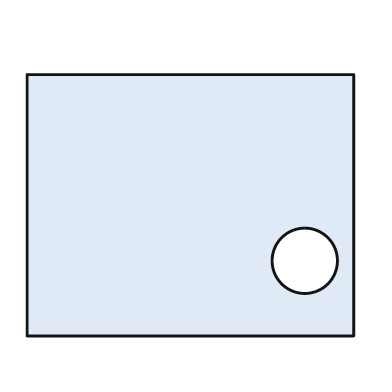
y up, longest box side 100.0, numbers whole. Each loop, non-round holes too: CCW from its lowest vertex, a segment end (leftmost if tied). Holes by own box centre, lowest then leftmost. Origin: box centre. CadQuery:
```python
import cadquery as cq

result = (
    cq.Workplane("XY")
    .moveTo(-50.0, -40.0)
    .lineTo(50.0, -40.0)
    .lineTo(50.0, 40.0)
    .lineTo(-50.0, 40.0)
    .close()
    .moveTo(35.0, -17.0)
    .circle(10.0)
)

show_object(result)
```